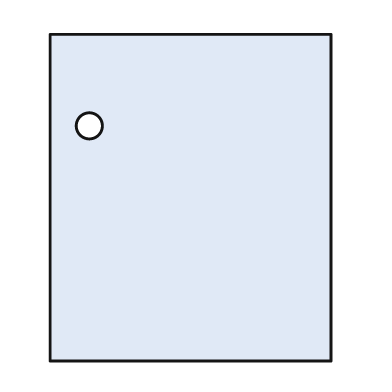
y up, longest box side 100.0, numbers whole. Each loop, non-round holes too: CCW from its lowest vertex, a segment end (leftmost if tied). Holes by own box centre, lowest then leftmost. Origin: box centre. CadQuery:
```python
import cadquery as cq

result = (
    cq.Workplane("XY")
    .moveTo(-43.0, -50.0)
    .lineTo(43.0, -50.0)
    .lineTo(43.0, 50.0)
    .lineTo(-43.0, 50.0)
    .close()
    .moveTo(-31.0, 22.0)
    .circle(4.0)
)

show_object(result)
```